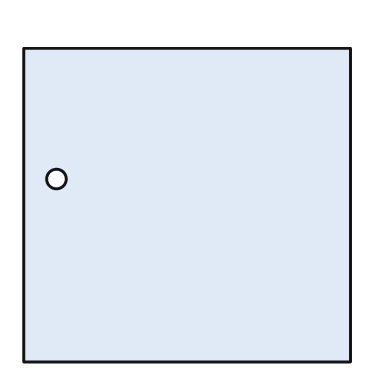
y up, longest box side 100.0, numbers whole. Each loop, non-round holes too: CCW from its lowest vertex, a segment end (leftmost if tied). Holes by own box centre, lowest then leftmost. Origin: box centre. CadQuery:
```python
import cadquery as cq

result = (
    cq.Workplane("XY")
    .moveTo(-50.0, -48.0)
    .lineTo(50.0, -48.0)
    .lineTo(50.0, 48.0)
    .lineTo(-50.0, 48.0)
    .close()
    .moveTo(-40.0, 8.0)
    .circle(3.0)
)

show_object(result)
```